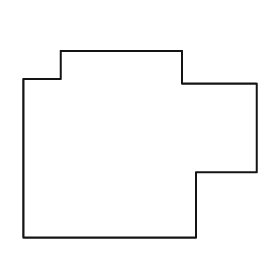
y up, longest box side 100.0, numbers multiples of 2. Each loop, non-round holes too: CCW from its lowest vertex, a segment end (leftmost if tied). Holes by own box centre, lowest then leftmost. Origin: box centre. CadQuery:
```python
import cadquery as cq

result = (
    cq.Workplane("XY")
    .moveTo(-50.0, -40.0)
    .lineTo(24.0, -40.0)
    .lineTo(24.0, -12.0)
    .lineTo(50.0, -12.0)
    .lineTo(50.0, 26.0)
    .lineTo(18.0, 26.0)
    .lineTo(18.0, 40.0)
    .lineTo(-34.0, 40.0)
    .lineTo(-34.0, 28.0)
    .lineTo(-50.0, 28.0)
    .close()
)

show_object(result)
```